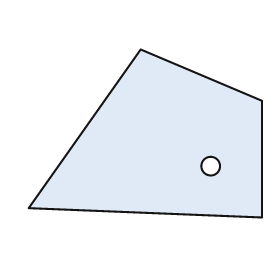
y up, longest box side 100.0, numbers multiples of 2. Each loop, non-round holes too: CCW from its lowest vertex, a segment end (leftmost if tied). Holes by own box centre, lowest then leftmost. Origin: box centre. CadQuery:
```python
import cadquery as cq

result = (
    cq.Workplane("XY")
    .moveTo(50.0, -36.0)
    .lineTo(50.0, 14.0)
    .lineTo(-2.0, 36.0)
    .lineTo(-50.0, -32.0)
    .close()
    .moveTo(28.0, -14.0)
    .circle(4.0)
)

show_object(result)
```